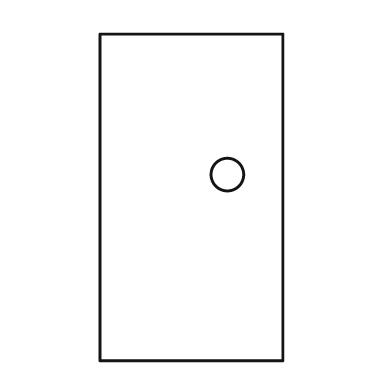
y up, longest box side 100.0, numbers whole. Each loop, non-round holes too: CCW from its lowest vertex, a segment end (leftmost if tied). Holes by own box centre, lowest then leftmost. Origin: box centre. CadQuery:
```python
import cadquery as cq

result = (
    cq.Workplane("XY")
    .moveTo(-28.0, -50.0)
    .lineTo(28.0, -50.0)
    .lineTo(28.0, 50.0)
    .lineTo(-28.0, 50.0)
    .close()
    .moveTo(11.0, 7.0)
    .circle(5.0)
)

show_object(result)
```